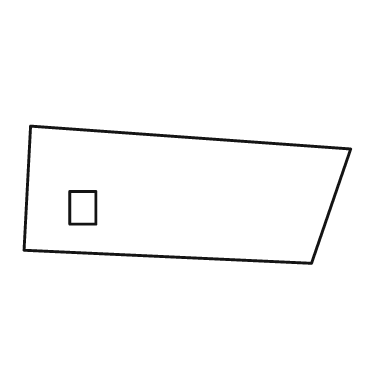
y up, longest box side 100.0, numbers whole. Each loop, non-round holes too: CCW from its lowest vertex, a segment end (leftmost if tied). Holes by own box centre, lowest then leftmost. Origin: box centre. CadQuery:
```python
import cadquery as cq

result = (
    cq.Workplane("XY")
    .moveTo(38.0, -21.0)
    .lineTo(50.0, 14.0)
    .lineTo(-48.0, 21.0)
    .lineTo(-50.0, -17.0)
    .close()
    .moveTo(-36.0, -9.0)
    .lineTo(-28.0, -9.0)
    .lineTo(-28.0, 1.0)
    .lineTo(-36.0, 1.0)
    .close()
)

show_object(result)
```